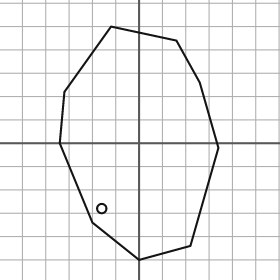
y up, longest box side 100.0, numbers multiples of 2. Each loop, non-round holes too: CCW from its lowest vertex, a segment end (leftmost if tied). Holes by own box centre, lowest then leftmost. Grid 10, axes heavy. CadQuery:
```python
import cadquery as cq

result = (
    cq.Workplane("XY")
    .moveTo(0.0, -50.0)
    .lineTo(22.0, -44.0)
    .lineTo(34.0, -2.0)
    .lineTo(26.0, 26.0)
    .lineTo(16.0, 44.0)
    .lineTo(-12.0, 50.0)
    .lineTo(-32.0, 22.0)
    .lineTo(-34.0, 0.0)
    .lineTo(-20.0, -34.0)
    .close()
    .moveTo(-16.0, -28.0)
    .circle(2.0)
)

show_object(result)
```